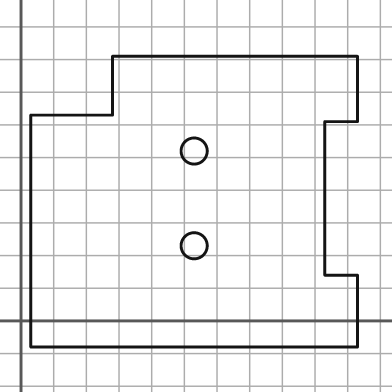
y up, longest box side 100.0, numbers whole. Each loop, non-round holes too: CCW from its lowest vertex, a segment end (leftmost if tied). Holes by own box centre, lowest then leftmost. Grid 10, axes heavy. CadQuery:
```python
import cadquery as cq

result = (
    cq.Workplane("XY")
    .moveTo(3.0, -8.0)
    .lineTo(103.0, -8.0)
    .lineTo(103.0, 14.0)
    .lineTo(93.0, 14.0)
    .lineTo(93.0, 61.0)
    .lineTo(103.0, 61.0)
    .lineTo(103.0, 81.0)
    .lineTo(28.0, 81.0)
    .lineTo(28.0, 63.0)
    .lineTo(3.0, 63.0)
    .close()
    .moveTo(53.0, 23.0)
    .circle(4.0)
    .moveTo(53.0, 52.0)
    .circle(4.0)
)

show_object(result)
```